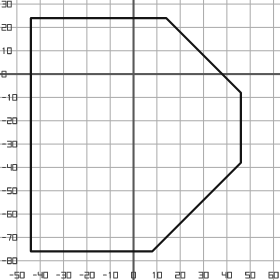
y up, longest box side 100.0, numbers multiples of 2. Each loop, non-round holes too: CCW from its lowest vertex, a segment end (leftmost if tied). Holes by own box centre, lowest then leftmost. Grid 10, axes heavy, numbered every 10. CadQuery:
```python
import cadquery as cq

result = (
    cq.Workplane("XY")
    .moveTo(-44.0, -76.0)
    .lineTo(8.0, -76.0)
    .lineTo(46.0, -38.0)
    .lineTo(46.0, -8.0)
    .lineTo(14.0, 24.0)
    .lineTo(-44.0, 24.0)
    .close()
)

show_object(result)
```